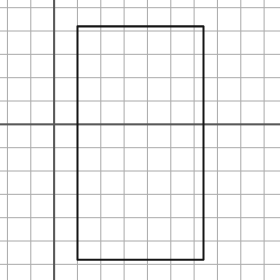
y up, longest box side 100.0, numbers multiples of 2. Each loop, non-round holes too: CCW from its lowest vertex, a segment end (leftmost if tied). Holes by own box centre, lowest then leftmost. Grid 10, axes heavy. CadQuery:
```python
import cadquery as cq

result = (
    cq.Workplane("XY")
    .moveTo(10.0, -58.0)
    .lineTo(64.0, -58.0)
    .lineTo(64.0, 42.0)
    .lineTo(10.0, 42.0)
    .close()
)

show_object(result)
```